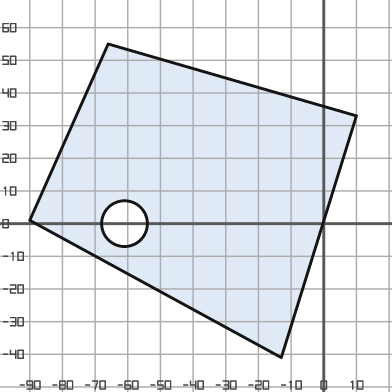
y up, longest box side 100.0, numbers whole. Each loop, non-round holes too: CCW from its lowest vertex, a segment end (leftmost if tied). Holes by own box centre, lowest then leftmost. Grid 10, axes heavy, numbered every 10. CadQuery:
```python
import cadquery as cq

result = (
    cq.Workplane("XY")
    .moveTo(-13.0, -41.0)
    .lineTo(10.0, 33.0)
    .lineTo(-66.0, 55.0)
    .lineTo(-90.0, 1.0)
    .close()
    .moveTo(-61.0, 0.0)
    .circle(7.0)
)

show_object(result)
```